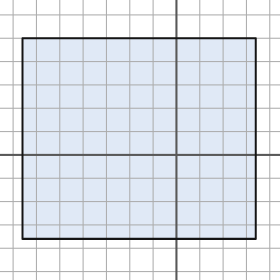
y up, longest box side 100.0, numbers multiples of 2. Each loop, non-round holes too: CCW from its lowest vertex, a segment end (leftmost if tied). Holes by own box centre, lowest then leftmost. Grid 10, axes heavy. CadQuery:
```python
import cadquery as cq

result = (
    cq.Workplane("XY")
    .moveTo(-66.0, -36.0)
    .lineTo(34.0, -36.0)
    .lineTo(34.0, 50.0)
    .lineTo(-66.0, 50.0)
    .close()
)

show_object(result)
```